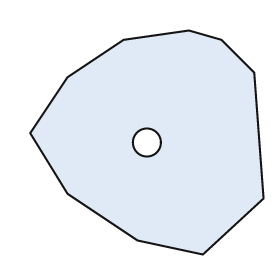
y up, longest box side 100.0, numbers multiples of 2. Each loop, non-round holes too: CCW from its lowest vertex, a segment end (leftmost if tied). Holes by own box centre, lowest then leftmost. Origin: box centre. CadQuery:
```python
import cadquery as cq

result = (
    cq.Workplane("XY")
    .moveTo(24.0, -48.0)
    .lineTo(50.0, -24.0)
    .lineTo(46.0, 30.0)
    .lineTo(32.0, 44.0)
    .lineTo(18.0, 48.0)
    .lineTo(-10.0, 44.0)
    .lineTo(-34.0, 28.0)
    .lineTo(-50.0, 4.0)
    .lineTo(-34.0, -22.0)
    .lineTo(-4.0, -42.0)
    .close()
    .moveTo(0.0, 0.0)
    .circle(6.0)
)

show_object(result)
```